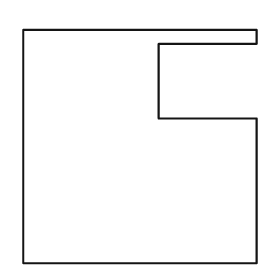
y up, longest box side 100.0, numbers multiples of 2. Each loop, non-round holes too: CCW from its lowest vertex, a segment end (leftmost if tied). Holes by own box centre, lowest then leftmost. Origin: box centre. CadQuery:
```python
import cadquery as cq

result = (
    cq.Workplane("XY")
    .moveTo(-50.0, -50.0)
    .lineTo(50.0, -50.0)
    .lineTo(50.0, 12.0)
    .lineTo(8.0, 12.0)
    .lineTo(8.0, 44.0)
    .lineTo(50.0, 44.0)
    .lineTo(50.0, 50.0)
    .lineTo(-50.0, 50.0)
    .close()
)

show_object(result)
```